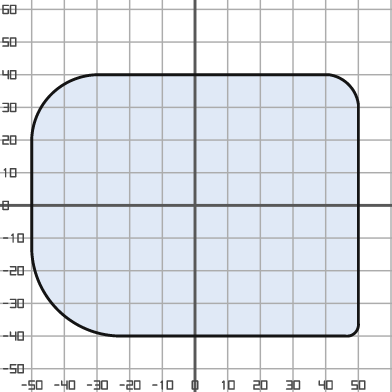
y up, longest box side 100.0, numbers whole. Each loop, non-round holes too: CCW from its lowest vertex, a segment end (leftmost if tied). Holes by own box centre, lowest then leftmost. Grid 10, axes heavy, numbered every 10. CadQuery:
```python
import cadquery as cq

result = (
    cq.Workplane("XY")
    .moveTo(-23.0, -40.0)
    .lineTo(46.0, -40.0)
    .threePointArc((49.0, -39.0), (50.0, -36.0))
    .lineTo(50.0, 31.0)
    .threePointArc((47.0, 37.0), (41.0, 40.0))
    .lineTo(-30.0, 40.0)
    .threePointArc((-44.0, 34.0), (-50.0, 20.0))
    .lineTo(-50.0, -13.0)
    .threePointArc((-42.0, -32.0), (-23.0, -40.0))
    .close()
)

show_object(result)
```